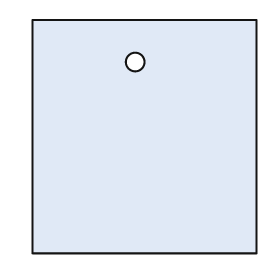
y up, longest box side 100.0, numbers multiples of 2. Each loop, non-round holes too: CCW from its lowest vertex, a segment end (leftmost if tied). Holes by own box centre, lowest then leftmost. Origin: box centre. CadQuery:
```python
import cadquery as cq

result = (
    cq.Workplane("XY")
    .moveTo(-48.0, -50.0)
    .lineTo(48.0, -50.0)
    .lineTo(48.0, 50.0)
    .lineTo(-48.0, 50.0)
    .close()
    .moveTo(-4.0, 32.0)
    .circle(4.0)
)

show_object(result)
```